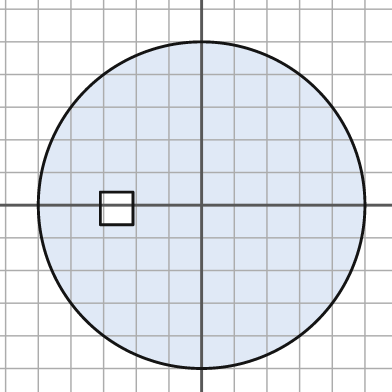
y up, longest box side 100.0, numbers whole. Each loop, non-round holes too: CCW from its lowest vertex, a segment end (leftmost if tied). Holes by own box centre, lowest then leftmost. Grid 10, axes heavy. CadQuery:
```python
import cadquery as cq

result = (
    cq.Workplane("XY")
    .moveTo(0.0, 0.0)
    .circle(50.0)
    .moveTo(-31.0, -6.0)
    .lineTo(-21.0, -6.0)
    .lineTo(-21.0, 4.0)
    .lineTo(-31.0, 4.0)
    .close()
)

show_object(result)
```